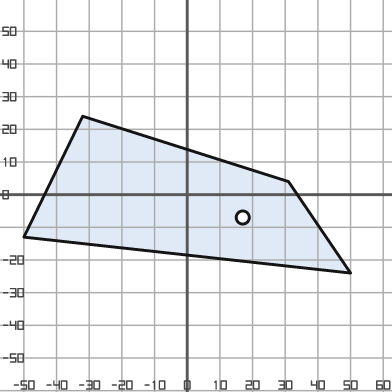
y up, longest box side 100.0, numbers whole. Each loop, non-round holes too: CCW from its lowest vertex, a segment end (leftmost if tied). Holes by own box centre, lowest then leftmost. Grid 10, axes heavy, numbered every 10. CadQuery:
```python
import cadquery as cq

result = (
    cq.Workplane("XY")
    .moveTo(50.0, -24.0)
    .lineTo(31.0, 4.0)
    .lineTo(-32.0, 24.0)
    .lineTo(-50.0, -13.0)
    .close()
    .moveTo(17.0, -7.0)
    .circle(2.0)
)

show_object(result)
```